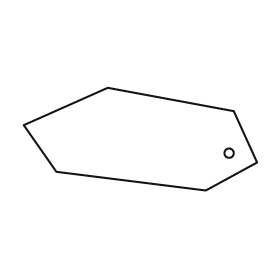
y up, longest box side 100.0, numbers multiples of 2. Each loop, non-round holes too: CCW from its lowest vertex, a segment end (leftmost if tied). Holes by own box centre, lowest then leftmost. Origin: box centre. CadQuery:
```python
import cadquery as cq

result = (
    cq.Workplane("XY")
    .moveTo(28.0, -22.0)
    .lineTo(50.0, -10.0)
    .lineTo(40.0, 12.0)
    .lineTo(-14.0, 22.0)
    .lineTo(-50.0, 6.0)
    .lineTo(-36.0, -14.0)
    .close()
    .moveTo(38.0, -6.0)
    .circle(2.0)
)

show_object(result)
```